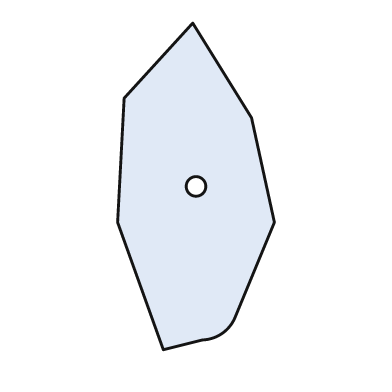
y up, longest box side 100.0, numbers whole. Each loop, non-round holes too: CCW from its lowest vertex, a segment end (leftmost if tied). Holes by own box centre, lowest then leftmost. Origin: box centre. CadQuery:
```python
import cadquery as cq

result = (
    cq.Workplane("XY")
    .moveTo(-10.0, -50.0)
    .lineTo(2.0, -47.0)
    .threePointArc((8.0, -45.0), (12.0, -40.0))
    .lineTo(24.0, -11.0)
    .lineTo(17.0, 21.0)
    .lineTo(-1.0, 50.0)
    .lineTo(-22.0, 27.0)
    .lineTo(-24.0, -11.0)
    .close()
    .moveTo(0.0, 0.0)
    .circle(3.0)
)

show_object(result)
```